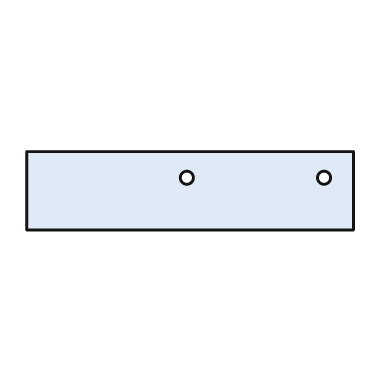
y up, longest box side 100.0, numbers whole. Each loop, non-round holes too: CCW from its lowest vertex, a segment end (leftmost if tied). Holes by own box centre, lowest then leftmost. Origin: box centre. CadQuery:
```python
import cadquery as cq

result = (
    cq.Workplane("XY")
    .moveTo(-50.0, -12.0)
    .lineTo(50.0, -12.0)
    .lineTo(50.0, 12.0)
    .lineTo(-50.0, 12.0)
    .close()
    .moveTo(-1.0, 4.0)
    .circle(2.0)
    .moveTo(41.0, 4.0)
    .circle(2.0)
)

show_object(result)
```